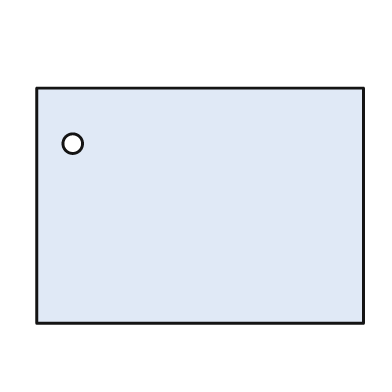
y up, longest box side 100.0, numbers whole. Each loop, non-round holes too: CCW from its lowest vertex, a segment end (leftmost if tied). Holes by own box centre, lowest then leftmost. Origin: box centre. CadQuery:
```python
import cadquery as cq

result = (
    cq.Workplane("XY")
    .moveTo(-50.0, -36.0)
    .lineTo(50.0, -36.0)
    .lineTo(50.0, 36.0)
    .lineTo(-50.0, 36.0)
    .close()
    .moveTo(-39.0, 19.0)
    .circle(3.0)
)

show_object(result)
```